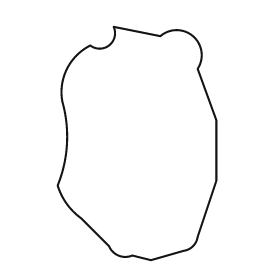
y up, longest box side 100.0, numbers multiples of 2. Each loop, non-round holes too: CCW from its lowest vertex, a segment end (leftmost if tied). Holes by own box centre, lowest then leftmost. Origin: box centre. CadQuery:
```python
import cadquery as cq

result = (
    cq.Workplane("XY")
    .moveTo(6.0, -50.0)
    .lineTo(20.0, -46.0)
    .threePointArc((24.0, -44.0), (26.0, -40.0))
    .lineTo(34.0, -16.0)
    .lineTo(34.0, 10.0)
    .lineTo(26.0, 32.0)
    .threePointArc((24.0, 46.0), (10.0, 46.0))
    .lineTo(-10.0, 50.0)
    .threePointArc((-12.0, 42.0), (-20.0, 42.0))
    .threePointArc((-30.0, 32.0), (-32.0, 18.0))
    .threePointArc((-30.0, 0.0), (-34.0, -18.0))
    .threePointArc((-30.0, -26.0), (-24.0, -32.0))
    .lineTo(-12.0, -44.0)
    .threePointArc((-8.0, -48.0), (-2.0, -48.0))
    .close()
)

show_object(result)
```